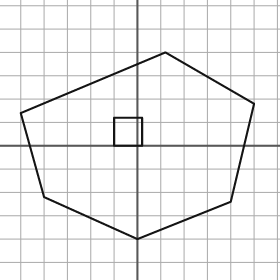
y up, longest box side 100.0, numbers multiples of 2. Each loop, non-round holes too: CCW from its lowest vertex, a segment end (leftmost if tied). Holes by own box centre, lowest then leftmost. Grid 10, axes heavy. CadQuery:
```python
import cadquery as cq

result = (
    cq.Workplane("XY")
    .moveTo(0.0, -40.0)
    .lineTo(40.0, -24.0)
    .lineTo(50.0, 18.0)
    .lineTo(12.0, 40.0)
    .lineTo(-50.0, 14.0)
    .lineTo(-40.0, -22.0)
    .close()
    .moveTo(-10.0, 0.0)
    .lineTo(2.0, 0.0)
    .lineTo(2.0, 12.0)
    .lineTo(-10.0, 12.0)
    .close()
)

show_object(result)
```